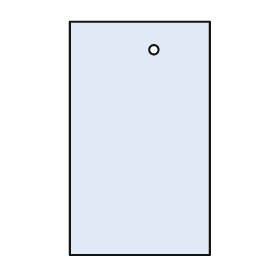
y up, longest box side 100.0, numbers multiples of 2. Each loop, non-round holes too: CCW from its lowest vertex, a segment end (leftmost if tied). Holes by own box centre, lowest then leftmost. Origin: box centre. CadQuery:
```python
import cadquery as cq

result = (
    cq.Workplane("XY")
    .moveTo(-30.0, -50.0)
    .lineTo(30.0, -50.0)
    .lineTo(30.0, 50.0)
    .lineTo(-30.0, 50.0)
    .close()
    .moveTo(6.0, 38.0)
    .circle(2.0)
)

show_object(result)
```